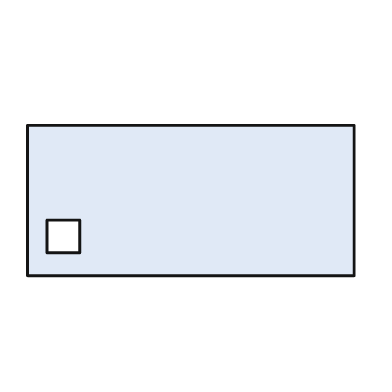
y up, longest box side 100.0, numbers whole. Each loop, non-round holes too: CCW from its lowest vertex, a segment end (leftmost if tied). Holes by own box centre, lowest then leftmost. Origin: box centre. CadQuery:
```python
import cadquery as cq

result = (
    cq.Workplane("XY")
    .moveTo(-50.0, -23.0)
    .lineTo(50.0, -23.0)
    .lineTo(50.0, 23.0)
    .lineTo(-50.0, 23.0)
    .close()
    .moveTo(-44.0, -16.0)
    .lineTo(-34.0, -16.0)
    .lineTo(-34.0, -6.0)
    .lineTo(-44.0, -6.0)
    .close()
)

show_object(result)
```